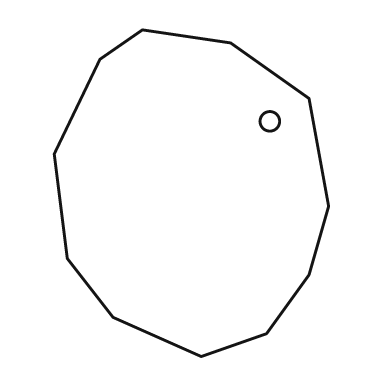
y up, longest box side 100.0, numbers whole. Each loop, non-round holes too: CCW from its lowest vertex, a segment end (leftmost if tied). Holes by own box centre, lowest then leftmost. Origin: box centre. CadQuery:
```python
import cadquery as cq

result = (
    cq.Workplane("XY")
    .moveTo(3.0, -50.0)
    .lineTo(23.0, -43.0)
    .lineTo(36.0, -25.0)
    .lineTo(42.0, -4.0)
    .lineTo(36.0, 29.0)
    .lineTo(12.0, 46.0)
    .lineTo(-15.0, 50.0)
    .lineTo(-28.0, 41.0)
    .lineTo(-42.0, 12.0)
    .lineTo(-38.0, -20.0)
    .lineTo(-24.0, -38.0)
    .close()
    .moveTo(24.0, 22.0)
    .circle(3.0)
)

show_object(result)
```